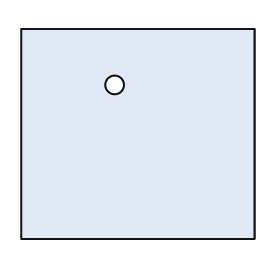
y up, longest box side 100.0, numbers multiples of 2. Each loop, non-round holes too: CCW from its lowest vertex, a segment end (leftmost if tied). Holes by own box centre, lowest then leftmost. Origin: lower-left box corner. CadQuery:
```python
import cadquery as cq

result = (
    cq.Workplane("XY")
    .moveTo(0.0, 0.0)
    .lineTo(100.0, 0.0)
    .lineTo(100.0, 90.0)
    .lineTo(0.0, 90.0)
    .close()
    .moveTo(40.0, 66.0)
    .circle(4.0)
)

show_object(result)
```